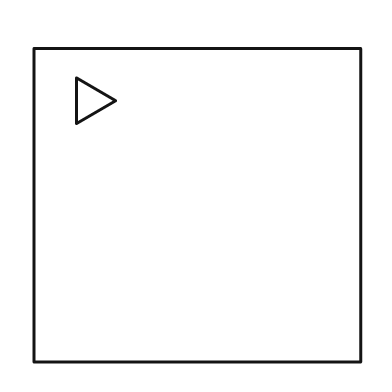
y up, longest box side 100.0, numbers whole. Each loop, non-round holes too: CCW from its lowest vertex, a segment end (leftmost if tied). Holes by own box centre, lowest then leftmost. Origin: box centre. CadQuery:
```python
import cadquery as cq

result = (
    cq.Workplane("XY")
    .moveTo(-50.0, -48.0)
    .lineTo(50.0, -48.0)
    .lineTo(50.0, 48.0)
    .lineTo(-50.0, 48.0)
    .close()
    .moveTo(-37.0, 25.0)
    .lineTo(-25.0, 32.0)
    .lineTo(-37.0, 39.0)
    .close()
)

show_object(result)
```